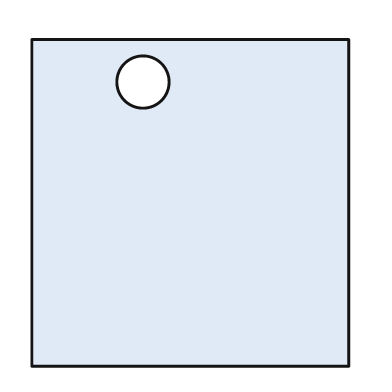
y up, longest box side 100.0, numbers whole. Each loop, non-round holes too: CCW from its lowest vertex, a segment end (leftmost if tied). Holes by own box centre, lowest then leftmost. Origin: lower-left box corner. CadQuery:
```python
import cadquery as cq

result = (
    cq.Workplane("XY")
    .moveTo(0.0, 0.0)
    .lineTo(97.0, 0.0)
    .lineTo(97.0, 100.0)
    .lineTo(0.0, 100.0)
    .close()
    .moveTo(34.0, 87.0)
    .circle(8.0)
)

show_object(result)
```